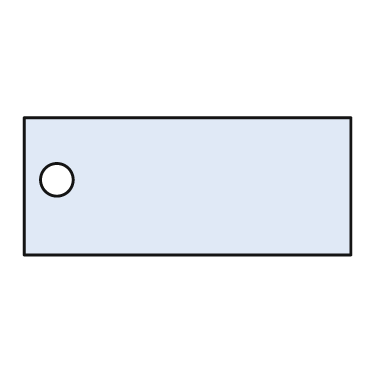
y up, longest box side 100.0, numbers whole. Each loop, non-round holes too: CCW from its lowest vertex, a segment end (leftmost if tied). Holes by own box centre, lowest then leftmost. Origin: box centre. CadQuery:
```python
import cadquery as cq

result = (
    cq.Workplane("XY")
    .moveTo(-50.0, -21.0)
    .lineTo(50.0, -21.0)
    .lineTo(50.0, 21.0)
    .lineTo(-50.0, 21.0)
    .close()
    .moveTo(-40.0, 2.0)
    .circle(5.0)
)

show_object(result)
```